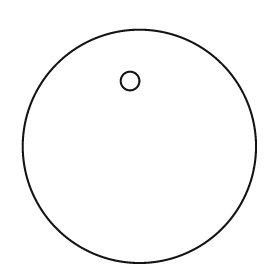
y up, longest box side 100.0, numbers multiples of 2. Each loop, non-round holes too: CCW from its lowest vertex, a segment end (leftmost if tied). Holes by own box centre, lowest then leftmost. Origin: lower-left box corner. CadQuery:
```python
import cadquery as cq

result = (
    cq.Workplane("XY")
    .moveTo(50.0, 50.0)
    .circle(50.0)
    .moveTo(46.0, 78.0)
    .circle(4.0)
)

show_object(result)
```